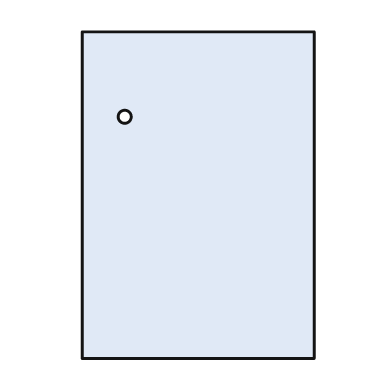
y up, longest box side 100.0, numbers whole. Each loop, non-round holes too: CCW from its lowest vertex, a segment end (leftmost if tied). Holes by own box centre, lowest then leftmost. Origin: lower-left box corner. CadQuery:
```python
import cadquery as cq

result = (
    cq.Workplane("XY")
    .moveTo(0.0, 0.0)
    .lineTo(71.0, 0.0)
    .lineTo(71.0, 100.0)
    .lineTo(0.0, 100.0)
    .close()
    .moveTo(13.0, 74.0)
    .circle(2.0)
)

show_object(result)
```